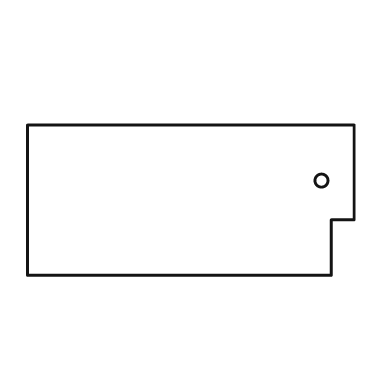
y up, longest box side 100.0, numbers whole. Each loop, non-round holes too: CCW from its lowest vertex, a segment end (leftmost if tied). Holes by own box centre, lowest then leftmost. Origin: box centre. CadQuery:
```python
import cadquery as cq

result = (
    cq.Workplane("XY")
    .moveTo(-50.0, -23.0)
    .lineTo(43.0, -23.0)
    .lineTo(43.0, -6.0)
    .lineTo(50.0, -6.0)
    .lineTo(50.0, 23.0)
    .lineTo(-50.0, 23.0)
    .close()
    .moveTo(40.0, 6.0)
    .circle(2.0)
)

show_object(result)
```